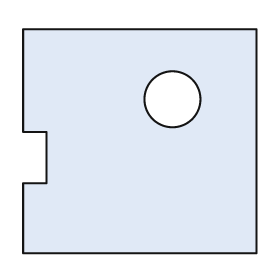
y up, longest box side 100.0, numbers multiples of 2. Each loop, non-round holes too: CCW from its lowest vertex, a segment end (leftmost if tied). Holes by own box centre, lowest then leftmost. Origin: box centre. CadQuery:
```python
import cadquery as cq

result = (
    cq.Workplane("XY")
    .moveTo(-50.0, -48.0)
    .lineTo(50.0, -48.0)
    .lineTo(50.0, 48.0)
    .lineTo(-50.0, 48.0)
    .lineTo(-50.0, 4.0)
    .lineTo(-40.0, 4.0)
    .lineTo(-40.0, -18.0)
    .lineTo(-50.0, -18.0)
    .close()
    .moveTo(14.0, 18.0)
    .circle(12.0)
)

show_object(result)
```